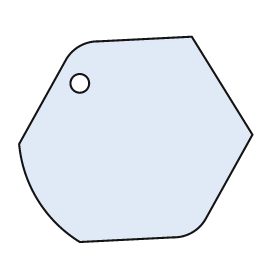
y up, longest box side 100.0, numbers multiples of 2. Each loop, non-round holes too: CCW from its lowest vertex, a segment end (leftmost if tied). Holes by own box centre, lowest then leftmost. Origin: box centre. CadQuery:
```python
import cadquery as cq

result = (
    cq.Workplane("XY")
    .moveTo(-24.0, -44.0)
    .lineTo(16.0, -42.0)
    .threePointArc((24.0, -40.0), (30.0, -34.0))
    .lineTo(50.0, 2.0)
    .lineTo(24.0, 44.0)
    .lineTo(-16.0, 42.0)
    .threePointArc((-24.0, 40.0), (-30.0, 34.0))
    .lineTo(-50.0, -2.0)
    .threePointArc((-42.0, -26.0), (-24.0, -44.0))
    .close()
    .moveTo(-24.0, 24.0)
    .circle(4.0)
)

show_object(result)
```